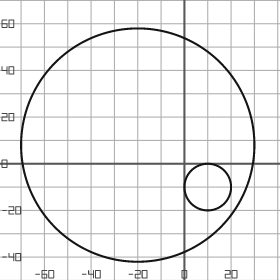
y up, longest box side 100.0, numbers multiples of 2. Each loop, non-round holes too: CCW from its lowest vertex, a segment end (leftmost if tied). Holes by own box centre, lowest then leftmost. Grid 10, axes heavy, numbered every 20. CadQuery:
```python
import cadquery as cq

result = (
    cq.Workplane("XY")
    .moveTo(-20.0, 8.0)
    .circle(50.0)
    .moveTo(10.0, -10.0)
    .circle(10.0)
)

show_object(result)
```